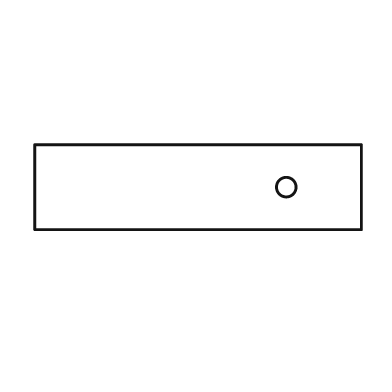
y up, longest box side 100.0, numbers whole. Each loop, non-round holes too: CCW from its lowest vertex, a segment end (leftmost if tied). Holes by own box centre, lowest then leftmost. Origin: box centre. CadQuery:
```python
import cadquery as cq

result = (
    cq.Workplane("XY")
    .moveTo(-50.0, -13.0)
    .lineTo(50.0, -13.0)
    .lineTo(50.0, 13.0)
    .lineTo(-50.0, 13.0)
    .close()
    .moveTo(27.0, 0.0)
    .circle(3.0)
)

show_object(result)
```